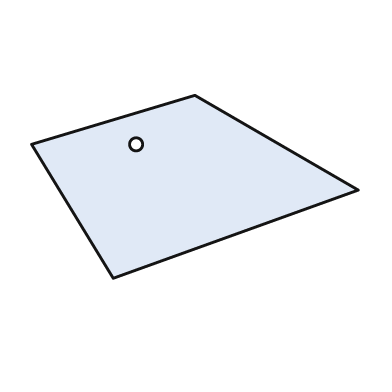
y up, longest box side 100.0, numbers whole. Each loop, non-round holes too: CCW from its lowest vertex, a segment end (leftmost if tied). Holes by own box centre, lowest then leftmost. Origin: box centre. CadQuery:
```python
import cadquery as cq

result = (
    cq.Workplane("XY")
    .moveTo(-25.0, -28.0)
    .lineTo(50.0, -1.0)
    .lineTo(0.0, 28.0)
    .lineTo(-50.0, 13.0)
    .close()
    .moveTo(-18.0, 13.0)
    .circle(2.0)
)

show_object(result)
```